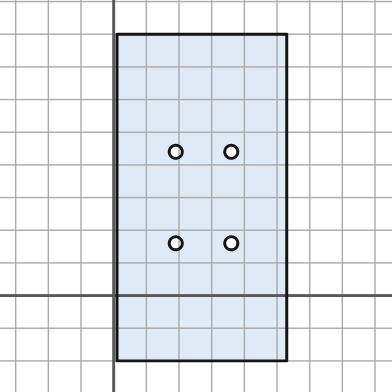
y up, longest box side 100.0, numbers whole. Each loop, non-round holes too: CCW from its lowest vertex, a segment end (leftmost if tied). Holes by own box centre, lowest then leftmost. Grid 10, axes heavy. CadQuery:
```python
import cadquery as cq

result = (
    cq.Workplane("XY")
    .moveTo(1.0, -20.0)
    .lineTo(53.0, -20.0)
    .lineTo(53.0, 80.0)
    .lineTo(1.0, 80.0)
    .close()
    .moveTo(19.0, 16.0)
    .circle(2.0)
    .moveTo(36.0, 16.0)
    .circle(2.0)
    .moveTo(19.0, 44.0)
    .circle(2.0)
    .moveTo(36.0, 44.0)
    .circle(2.0)
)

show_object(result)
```